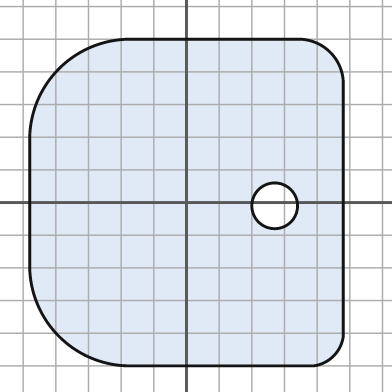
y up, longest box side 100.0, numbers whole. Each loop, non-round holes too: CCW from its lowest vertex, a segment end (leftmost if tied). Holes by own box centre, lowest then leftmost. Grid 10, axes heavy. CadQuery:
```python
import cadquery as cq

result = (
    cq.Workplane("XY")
    .moveTo(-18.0, -50.0)
    .lineTo(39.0, -50.0)
    .threePointArc((45.0, -47.0), (48.0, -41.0))
    .lineTo(48.0, 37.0)
    .threePointArc((44.0, 46.0), (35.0, 50.0))
    .lineTo(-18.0, 50.0)
    .threePointArc((-39.0, 41.0), (-48.0, 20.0))
    .lineTo(-48.0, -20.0)
    .threePointArc((-39.0, -41.0), (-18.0, -50.0))
    .close()
    .moveTo(27.0, -1.0)
    .circle(7.0)
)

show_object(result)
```